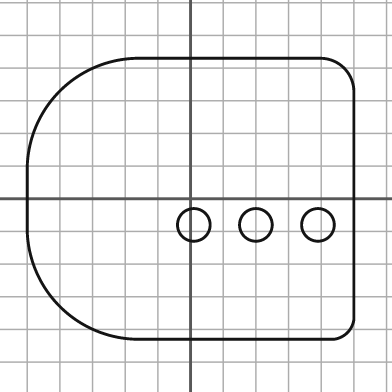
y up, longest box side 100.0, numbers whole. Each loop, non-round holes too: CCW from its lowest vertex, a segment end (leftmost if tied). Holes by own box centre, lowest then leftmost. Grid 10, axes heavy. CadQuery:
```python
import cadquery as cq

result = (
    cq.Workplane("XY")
    .moveTo(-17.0, -43.0)
    .lineTo(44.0, -43.0)
    .threePointArc((48.0, -41.0), (50.0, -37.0))
    .lineTo(50.0, 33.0)
    .threePointArc((47.0, 40.0), (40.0, 43.0))
    .lineTo(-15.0, 43.0)
    .threePointArc((-40.0, 33.0), (-50.0, 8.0))
    .lineTo(-50.0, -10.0)
    .threePointArc((-40.0, -33.0), (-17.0, -43.0))
    .close()
    .moveTo(1.0, -8.0)
    .circle(5.0)
    .moveTo(20.0, -8.0)
    .circle(5.0)
    .moveTo(39.0, -8.0)
    .circle(5.0)
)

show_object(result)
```